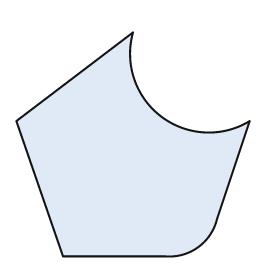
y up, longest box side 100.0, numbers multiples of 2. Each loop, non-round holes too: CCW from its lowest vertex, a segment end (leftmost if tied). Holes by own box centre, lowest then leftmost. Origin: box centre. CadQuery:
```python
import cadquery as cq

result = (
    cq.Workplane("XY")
    .moveTo(-30.0, -48.0)
    .lineTo(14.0, -48.0)
    .threePointArc((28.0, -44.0), (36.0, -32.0))
    .lineTo(50.0, 10.0)
    .threePointArc((12.0, 12.0), (0.0, 48.0))
    .lineTo(-50.0, 10.0)
    .close()
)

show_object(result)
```